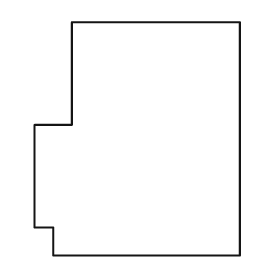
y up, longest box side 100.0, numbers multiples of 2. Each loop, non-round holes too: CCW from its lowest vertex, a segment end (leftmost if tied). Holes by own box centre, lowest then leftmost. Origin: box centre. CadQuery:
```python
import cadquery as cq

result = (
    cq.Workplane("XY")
    .moveTo(-36.0, -50.0)
    .lineTo(44.0, -50.0)
    .lineTo(44.0, 50.0)
    .lineTo(-28.0, 50.0)
    .lineTo(-28.0, 6.0)
    .lineTo(-44.0, 6.0)
    .lineTo(-44.0, -38.0)
    .lineTo(-36.0, -38.0)
    .close()
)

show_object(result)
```